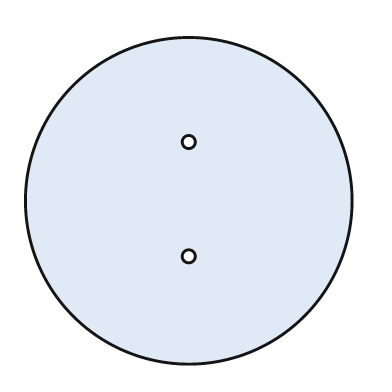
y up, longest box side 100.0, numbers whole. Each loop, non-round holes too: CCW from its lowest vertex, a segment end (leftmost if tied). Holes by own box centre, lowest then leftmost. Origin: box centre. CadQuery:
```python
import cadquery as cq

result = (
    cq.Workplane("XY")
    .moveTo(0.0, 0.0)
    .circle(50.0)
    .moveTo(0.0, -17.0)
    .circle(2.0)
    .moveTo(0.0, 18.0)
    .circle(2.0)
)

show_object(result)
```